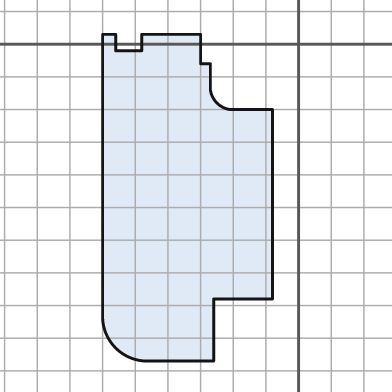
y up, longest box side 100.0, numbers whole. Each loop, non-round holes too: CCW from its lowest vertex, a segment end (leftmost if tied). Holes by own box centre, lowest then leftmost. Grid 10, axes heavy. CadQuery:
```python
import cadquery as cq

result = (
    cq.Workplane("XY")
    .moveTo(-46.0, -97.0)
    .lineTo(-26.0, -97.0)
    .lineTo(-26.0, -78.0)
    .lineTo(-8.0, -78.0)
    .lineTo(-8.0, -20.0)
    .lineTo(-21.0, -20.0)
    .threePointArc((-25.0, -18.0), (-27.0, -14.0))
    .lineTo(-27.0, -6.0)
    .lineTo(-30.0, -6.0)
    .lineTo(-30.0, 3.0)
    .lineTo(-48.0, 3.0)
    .lineTo(-48.0, -2.0)
    .lineTo(-56.0, -2.0)
    .lineTo(-56.0, 3.0)
    .lineTo(-60.0, 3.0)
    .lineTo(-60.0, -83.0)
    .threePointArc((-56.0, -93.0), (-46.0, -97.0))
    .close()
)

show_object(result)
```